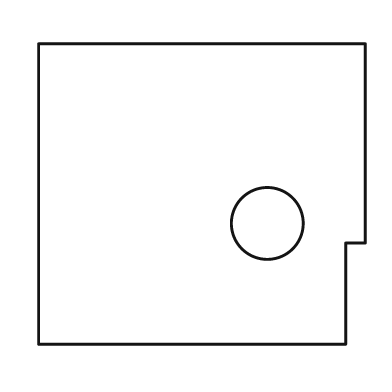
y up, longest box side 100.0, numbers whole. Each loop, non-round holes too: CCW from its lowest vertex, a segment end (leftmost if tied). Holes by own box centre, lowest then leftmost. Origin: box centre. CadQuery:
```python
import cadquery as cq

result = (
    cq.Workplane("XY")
    .moveTo(-50.0, -46.0)
    .lineTo(44.0, -46.0)
    .lineTo(44.0, -15.0)
    .lineTo(50.0, -15.0)
    .lineTo(50.0, 46.0)
    .lineTo(-50.0, 46.0)
    .close()
    .moveTo(20.0, -9.0)
    .circle(11.0)
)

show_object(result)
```